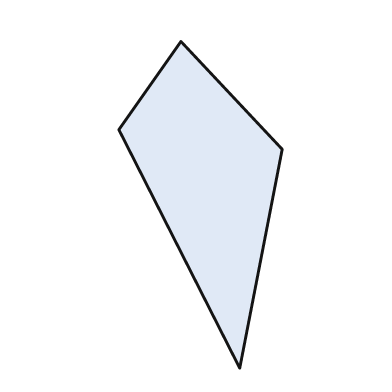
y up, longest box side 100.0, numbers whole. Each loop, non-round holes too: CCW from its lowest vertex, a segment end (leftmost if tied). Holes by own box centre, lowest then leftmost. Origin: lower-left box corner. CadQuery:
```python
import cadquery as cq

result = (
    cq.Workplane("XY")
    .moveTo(37.0, 0.0)
    .lineTo(50.0, 67.0)
    .lineTo(19.0, 100.0)
    .lineTo(0.0, 73.0)
    .close()
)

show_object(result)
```